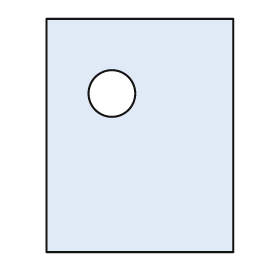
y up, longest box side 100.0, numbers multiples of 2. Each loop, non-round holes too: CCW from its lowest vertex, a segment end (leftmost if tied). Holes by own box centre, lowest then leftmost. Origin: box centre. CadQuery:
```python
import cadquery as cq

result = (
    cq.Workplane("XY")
    .moveTo(-40.0, -50.0)
    .lineTo(40.0, -50.0)
    .lineTo(40.0, 50.0)
    .lineTo(-40.0, 50.0)
    .close()
    .moveTo(-12.0, 18.0)
    .circle(10.0)
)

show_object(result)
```